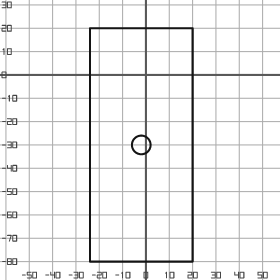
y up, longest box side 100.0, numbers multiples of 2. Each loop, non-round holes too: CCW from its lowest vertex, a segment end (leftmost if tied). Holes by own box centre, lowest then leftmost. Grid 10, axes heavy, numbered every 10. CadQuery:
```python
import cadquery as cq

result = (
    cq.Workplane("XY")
    .moveTo(-24.0, -80.0)
    .lineTo(20.0, -80.0)
    .lineTo(20.0, 20.0)
    .lineTo(-24.0, 20.0)
    .close()
    .moveTo(-2.0, -30.0)
    .circle(4.0)
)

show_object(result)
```